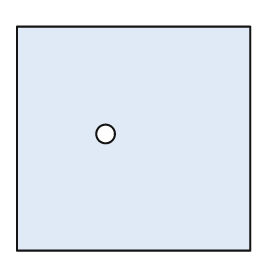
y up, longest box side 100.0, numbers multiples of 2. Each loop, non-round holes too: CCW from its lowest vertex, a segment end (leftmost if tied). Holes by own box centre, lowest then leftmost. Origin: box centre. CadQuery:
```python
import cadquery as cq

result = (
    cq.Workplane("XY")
    .moveTo(-50.0, -48.0)
    .lineTo(50.0, -48.0)
    .lineTo(50.0, 48.0)
    .lineTo(-50.0, 48.0)
    .close()
    .moveTo(-12.0, 2.0)
    .circle(4.0)
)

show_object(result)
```